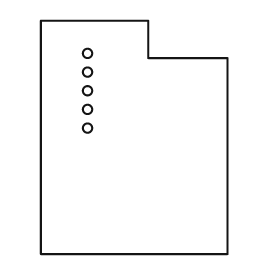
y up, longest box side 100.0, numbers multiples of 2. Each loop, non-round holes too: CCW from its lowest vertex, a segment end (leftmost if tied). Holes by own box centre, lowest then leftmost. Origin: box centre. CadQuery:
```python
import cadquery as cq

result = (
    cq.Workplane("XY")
    .moveTo(-40.0, -50.0)
    .lineTo(40.0, -50.0)
    .lineTo(40.0, 34.0)
    .lineTo(6.0, 34.0)
    .lineTo(6.0, 50.0)
    .lineTo(-40.0, 50.0)
    .close()
    .moveTo(-20.0, 4.0)
    .circle(2.0)
    .moveTo(-20.0, 12.0)
    .circle(2.0)
    .moveTo(-20.0, 20.0)
    .circle(2.0)
    .moveTo(-20.0, 28.0)
    .circle(2.0)
    .moveTo(-20.0, 36.0)
    .circle(2.0)
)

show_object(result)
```